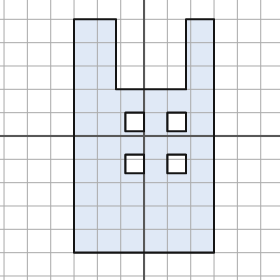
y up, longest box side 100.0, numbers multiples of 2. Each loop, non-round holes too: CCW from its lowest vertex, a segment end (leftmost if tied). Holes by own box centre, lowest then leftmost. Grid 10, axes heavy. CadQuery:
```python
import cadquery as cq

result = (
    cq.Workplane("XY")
    .moveTo(-30.0, -50.0)
    .lineTo(30.0, -50.0)
    .lineTo(30.0, 50.0)
    .lineTo(18.0, 50.0)
    .lineTo(18.0, 20.0)
    .lineTo(-12.0, 20.0)
    .lineTo(-12.0, 50.0)
    .lineTo(-30.0, 50.0)
    .close()
    .moveTo(-8.0, -16.0)
    .lineTo(0.0, -16.0)
    .lineTo(0.0, -8.0)
    .lineTo(-8.0, -8.0)
    .close()
    .moveTo(10.0, -16.0)
    .lineTo(18.0, -16.0)
    .lineTo(18.0, -8.0)
    .lineTo(10.0, -8.0)
    .close()
    .moveTo(-8.0, 2.0)
    .lineTo(0.0, 2.0)
    .lineTo(0.0, 10.0)
    .lineTo(-8.0, 10.0)
    .close()
    .moveTo(10.0, 2.0)
    .lineTo(18.0, 2.0)
    .lineTo(18.0, 10.0)
    .lineTo(10.0, 10.0)
    .close()
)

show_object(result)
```